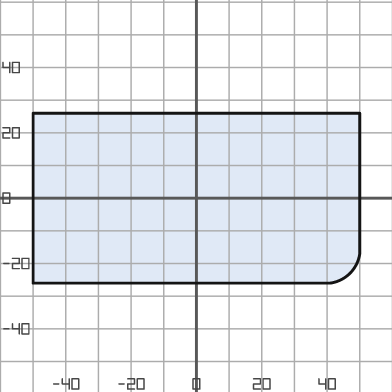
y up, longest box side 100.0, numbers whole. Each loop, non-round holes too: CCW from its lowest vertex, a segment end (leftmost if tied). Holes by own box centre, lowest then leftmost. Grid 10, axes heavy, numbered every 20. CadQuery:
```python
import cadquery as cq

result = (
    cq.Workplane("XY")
    .moveTo(-50.0, -26.0)
    .lineTo(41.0, -26.0)
    .threePointArc((47.0, -23.0), (50.0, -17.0))
    .lineTo(50.0, 26.0)
    .lineTo(-50.0, 26.0)
    .close()
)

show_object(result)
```